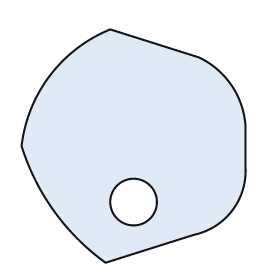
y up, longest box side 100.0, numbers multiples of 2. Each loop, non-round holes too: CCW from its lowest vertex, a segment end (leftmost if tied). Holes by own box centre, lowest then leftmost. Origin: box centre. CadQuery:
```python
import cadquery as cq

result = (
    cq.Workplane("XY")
    .moveTo(-12.0, -50.0)
    .lineTo(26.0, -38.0)
    .threePointArc((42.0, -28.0), (48.0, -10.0))
    .lineTo(48.0, 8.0)
    .threePointArc((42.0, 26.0), (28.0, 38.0))
    .lineTo(-10.0, 50.0)
    .threePointArc((-36.0, 30.0), (-48.0, 0.0))
    .threePointArc((-34.0, -28.0), (-12.0, -50.0))
    .close()
    .moveTo(0.0, -24.0)
    .circle(10.0)
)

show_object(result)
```